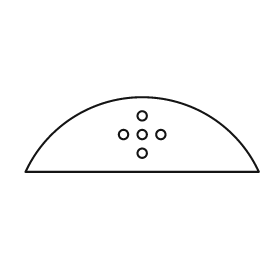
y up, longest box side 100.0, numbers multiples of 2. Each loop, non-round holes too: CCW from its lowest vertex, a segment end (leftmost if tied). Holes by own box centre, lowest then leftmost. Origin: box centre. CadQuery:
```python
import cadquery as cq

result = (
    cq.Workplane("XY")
    .moveTo(-50.0, -16.0)
    .lineTo(50.0, -16.0)
    .threePointArc((0.0, 16.0), (-50.0, -16.0))
    .close()
    .moveTo(0.0, -8.0)
    .circle(2.0)
    .moveTo(-8.0, 0.0)
    .circle(2.0)
    .moveTo(0.0, 0.0)
    .circle(2.0)
    .moveTo(8.0, 0.0)
    .circle(2.0)
    .moveTo(0.0, 8.0)
    .circle(2.0)
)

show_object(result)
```